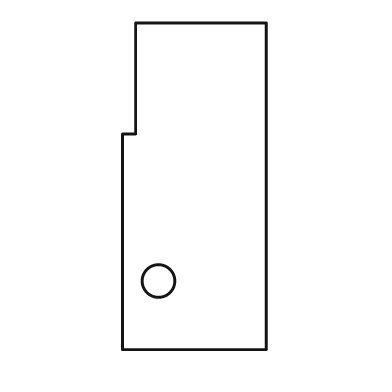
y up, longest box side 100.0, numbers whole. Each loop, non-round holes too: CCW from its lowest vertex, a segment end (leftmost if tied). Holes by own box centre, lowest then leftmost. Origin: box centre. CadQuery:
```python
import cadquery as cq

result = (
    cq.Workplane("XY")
    .moveTo(-22.0, -50.0)
    .lineTo(22.0, -50.0)
    .lineTo(22.0, 50.0)
    .lineTo(-18.0, 50.0)
    .lineTo(-18.0, 16.0)
    .lineTo(-22.0, 16.0)
    .close()
    .moveTo(-11.0, -29.0)
    .circle(5.0)
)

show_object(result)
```